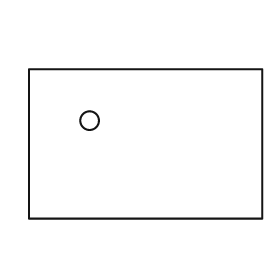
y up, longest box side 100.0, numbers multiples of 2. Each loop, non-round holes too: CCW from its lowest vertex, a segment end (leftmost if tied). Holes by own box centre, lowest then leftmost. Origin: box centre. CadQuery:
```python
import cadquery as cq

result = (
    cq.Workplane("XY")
    .moveTo(-50.0, -32.0)
    .lineTo(50.0, -32.0)
    .lineTo(50.0, 32.0)
    .lineTo(-50.0, 32.0)
    .close()
    .moveTo(-24.0, 10.0)
    .circle(4.0)
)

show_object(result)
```